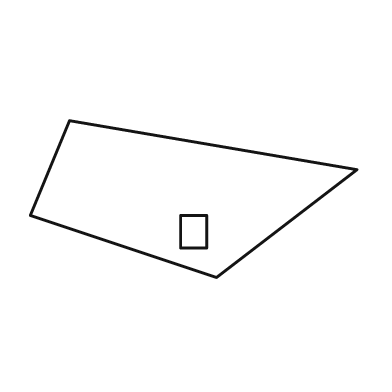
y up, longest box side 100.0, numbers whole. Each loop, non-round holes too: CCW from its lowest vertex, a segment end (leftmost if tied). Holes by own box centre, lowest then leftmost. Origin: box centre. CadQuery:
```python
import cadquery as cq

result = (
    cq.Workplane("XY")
    .moveTo(7.0, -24.0)
    .lineTo(50.0, 9.0)
    .lineTo(-38.0, 24.0)
    .lineTo(-50.0, -5.0)
    .close()
    .moveTo(-4.0, -15.0)
    .lineTo(4.0, -15.0)
    .lineTo(4.0, -5.0)
    .lineTo(-4.0, -5.0)
    .close()
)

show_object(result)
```